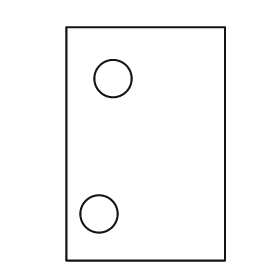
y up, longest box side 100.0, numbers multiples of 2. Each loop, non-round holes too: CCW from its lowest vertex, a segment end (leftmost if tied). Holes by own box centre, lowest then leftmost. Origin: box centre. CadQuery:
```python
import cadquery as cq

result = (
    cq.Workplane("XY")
    .moveTo(-34.0, -50.0)
    .lineTo(34.0, -50.0)
    .lineTo(34.0, 50.0)
    .lineTo(-34.0, 50.0)
    .close()
    .moveTo(-20.0, -30.0)
    .circle(8.0)
    .moveTo(-14.0, 28.0)
    .circle(8.0)
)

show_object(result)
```